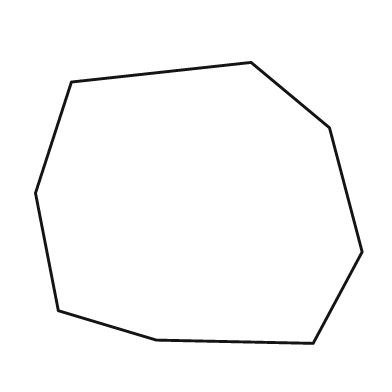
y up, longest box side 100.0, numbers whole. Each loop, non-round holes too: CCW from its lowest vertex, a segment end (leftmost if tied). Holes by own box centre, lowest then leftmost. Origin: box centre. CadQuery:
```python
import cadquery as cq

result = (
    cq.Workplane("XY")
    .moveTo(35.0, -43.0)
    .lineTo(50.0, -15.0)
    .lineTo(40.0, 23.0)
    .lineTo(16.0, 43.0)
    .lineTo(-39.0, 37.0)
    .lineTo(-50.0, 3.0)
    .lineTo(-43.0, -33.0)
    .lineTo(-13.0, -42.0)
    .close()
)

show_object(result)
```